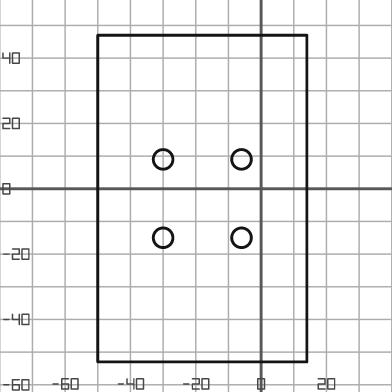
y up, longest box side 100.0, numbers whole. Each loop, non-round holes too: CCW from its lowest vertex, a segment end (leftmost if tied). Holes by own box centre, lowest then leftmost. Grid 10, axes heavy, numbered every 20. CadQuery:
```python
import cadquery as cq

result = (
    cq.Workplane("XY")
    .moveTo(-50.0, -53.0)
    .lineTo(14.0, -53.0)
    .lineTo(14.0, 47.0)
    .lineTo(-50.0, 47.0)
    .close()
    .moveTo(-30.0, -15.0)
    .circle(3.0)
    .moveTo(-6.0, -15.0)
    .circle(3.0)
    .moveTo(-30.0, 9.0)
    .circle(3.0)
    .moveTo(-6.0, 9.0)
    .circle(3.0)
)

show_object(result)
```